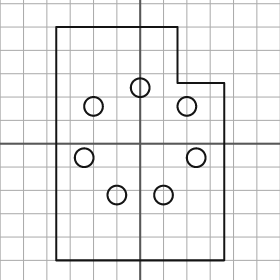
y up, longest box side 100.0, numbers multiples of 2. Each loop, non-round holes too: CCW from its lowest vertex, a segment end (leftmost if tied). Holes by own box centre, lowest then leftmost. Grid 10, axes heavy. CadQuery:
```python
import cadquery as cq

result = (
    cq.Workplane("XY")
    .moveTo(-36.0, -50.0)
    .lineTo(36.0, -50.0)
    .lineTo(36.0, 26.0)
    .lineTo(16.0, 26.0)
    .lineTo(16.0, 50.0)
    .lineTo(-36.0, 50.0)
    .close()
    .moveTo(-10.0, -22.0)
    .circle(4.0)
    .moveTo(10.0, -22.0)
    .circle(4.0)
    .moveTo(-24.0, -6.0)
    .circle(4.0)
    .moveTo(24.0, -6.0)
    .circle(4.0)
    .moveTo(-20.0, 16.0)
    .circle(4.0)
    .moveTo(20.0, 16.0)
    .circle(4.0)
    .moveTo(0.0, 24.0)
    .circle(4.0)
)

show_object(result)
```